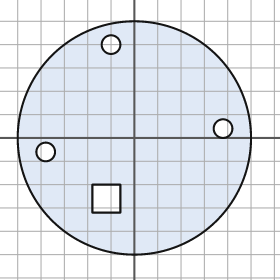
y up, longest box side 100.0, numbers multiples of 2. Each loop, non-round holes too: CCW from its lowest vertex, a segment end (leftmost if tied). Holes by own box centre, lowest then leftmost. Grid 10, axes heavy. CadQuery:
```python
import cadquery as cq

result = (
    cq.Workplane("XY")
    .moveTo(0.0, 0.0)
    .circle(50.0)
    .moveTo(-18.0, -32.0)
    .lineTo(-6.0, -32.0)
    .lineTo(-6.0, -20.0)
    .lineTo(-18.0, -20.0)
    .close()
    .moveTo(-38.0, -6.0)
    .circle(4.0)
    .moveTo(38.0, 4.0)
    .circle(4.0)
    .moveTo(-10.0, 40.0)
    .circle(4.0)
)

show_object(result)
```